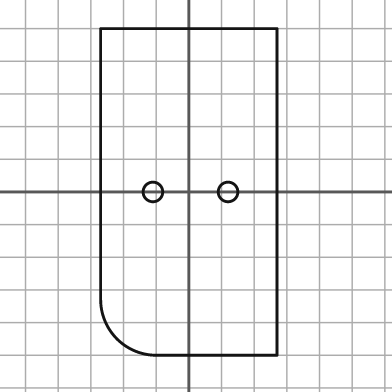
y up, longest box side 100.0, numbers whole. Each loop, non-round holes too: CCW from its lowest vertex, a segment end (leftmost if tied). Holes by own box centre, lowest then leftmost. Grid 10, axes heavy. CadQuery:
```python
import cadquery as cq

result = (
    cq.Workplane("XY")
    .moveTo(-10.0, -50.0)
    .lineTo(27.0, -50.0)
    .lineTo(27.0, 50.0)
    .lineTo(-27.0, 50.0)
    .lineTo(-27.0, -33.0)
    .threePointArc((-22.0, -45.0), (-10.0, -50.0))
    .close()
    .moveTo(-11.0, 0.0)
    .circle(3.0)
    .moveTo(12.0, 0.0)
    .circle(3.0)
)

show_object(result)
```